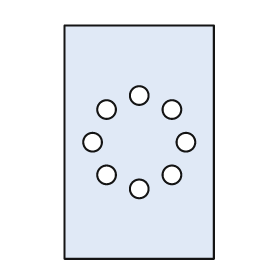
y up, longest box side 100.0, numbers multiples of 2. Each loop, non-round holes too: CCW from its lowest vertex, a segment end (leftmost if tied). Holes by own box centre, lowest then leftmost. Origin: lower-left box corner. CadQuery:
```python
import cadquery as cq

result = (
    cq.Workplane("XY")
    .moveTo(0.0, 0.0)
    .lineTo(64.0, 0.0)
    .lineTo(64.0, 100.0)
    .lineTo(0.0, 100.0)
    .close()
    .moveTo(32.0, 30.0)
    .circle(4.0)
    .moveTo(18.0, 36.0)
    .circle(4.0)
    .moveTo(46.0, 36.0)
    .circle(4.0)
    .moveTo(12.0, 50.0)
    .circle(4.0)
    .moveTo(52.0, 50.0)
    .circle(4.0)
    .moveTo(18.0, 64.0)
    .circle(4.0)
    .moveTo(46.0, 64.0)
    .circle(4.0)
    .moveTo(32.0, 70.0)
    .circle(4.0)
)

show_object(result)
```